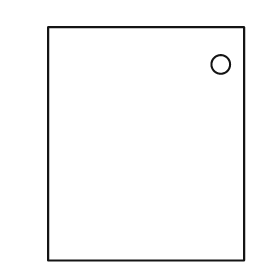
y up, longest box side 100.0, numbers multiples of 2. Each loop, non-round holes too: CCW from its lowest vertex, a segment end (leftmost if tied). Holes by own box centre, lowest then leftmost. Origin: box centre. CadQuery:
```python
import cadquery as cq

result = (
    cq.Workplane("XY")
    .moveTo(-42.0, -50.0)
    .lineTo(42.0, -50.0)
    .lineTo(42.0, 50.0)
    .lineTo(-42.0, 50.0)
    .close()
    .moveTo(32.0, 34.0)
    .circle(4.0)
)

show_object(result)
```